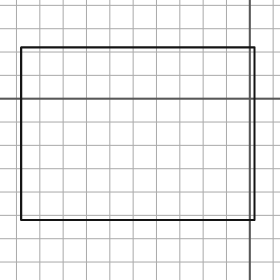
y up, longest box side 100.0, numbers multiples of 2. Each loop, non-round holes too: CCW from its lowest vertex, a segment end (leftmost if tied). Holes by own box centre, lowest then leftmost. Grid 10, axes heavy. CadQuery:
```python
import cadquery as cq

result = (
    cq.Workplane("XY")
    .moveTo(-98.0, -52.0)
    .lineTo(2.0, -52.0)
    .lineTo(2.0, 22.0)
    .lineTo(-98.0, 22.0)
    .close()
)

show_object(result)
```